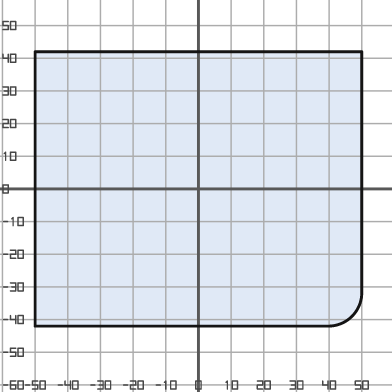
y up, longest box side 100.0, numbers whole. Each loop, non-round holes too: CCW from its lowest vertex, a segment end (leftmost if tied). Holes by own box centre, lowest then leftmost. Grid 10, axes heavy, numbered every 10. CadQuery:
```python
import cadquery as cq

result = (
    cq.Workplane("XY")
    .moveTo(-50.0, -42.0)
    .lineTo(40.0, -42.0)
    .threePointArc((47.0, -39.0), (50.0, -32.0))
    .lineTo(50.0, 42.0)
    .lineTo(-50.0, 42.0)
    .close()
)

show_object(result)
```